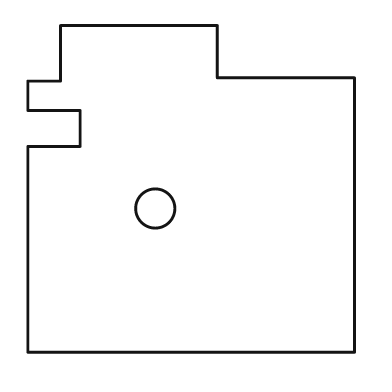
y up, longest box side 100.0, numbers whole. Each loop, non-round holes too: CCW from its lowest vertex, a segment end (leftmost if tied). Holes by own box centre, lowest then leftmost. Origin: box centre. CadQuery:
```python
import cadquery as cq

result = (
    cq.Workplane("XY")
    .moveTo(-50.0, -50.0)
    .lineTo(50.0, -50.0)
    .lineTo(50.0, 34.0)
    .lineTo(8.0, 34.0)
    .lineTo(8.0, 50.0)
    .lineTo(-40.0, 50.0)
    .lineTo(-40.0, 33.0)
    .lineTo(-50.0, 33.0)
    .lineTo(-50.0, 24.0)
    .lineTo(-34.0, 24.0)
    .lineTo(-34.0, 13.0)
    .lineTo(-50.0, 13.0)
    .close()
    .moveTo(-11.0, -6.0)
    .circle(6.0)
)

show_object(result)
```